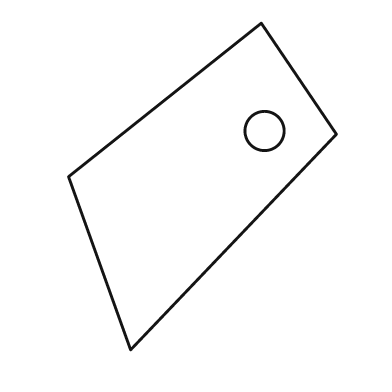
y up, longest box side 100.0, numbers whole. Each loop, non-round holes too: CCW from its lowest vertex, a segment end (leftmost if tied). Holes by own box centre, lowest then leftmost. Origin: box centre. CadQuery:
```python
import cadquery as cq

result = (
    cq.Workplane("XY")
    .moveTo(-22.0, -50.0)
    .lineTo(41.0, 16.0)
    .lineTo(18.0, 50.0)
    .lineTo(-41.0, 3.0)
    .close()
    .moveTo(19.0, 17.0)
    .circle(6.0)
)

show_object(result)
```